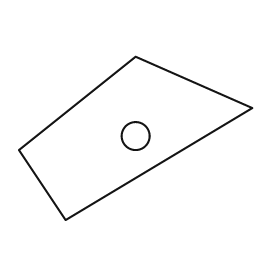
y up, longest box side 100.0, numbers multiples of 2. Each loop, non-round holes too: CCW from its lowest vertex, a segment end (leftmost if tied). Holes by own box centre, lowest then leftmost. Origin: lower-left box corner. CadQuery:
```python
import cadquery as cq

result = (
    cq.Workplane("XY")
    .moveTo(20.0, 0.0)
    .lineTo(100.0, 48.0)
    .lineTo(50.0, 70.0)
    .lineTo(0.0, 30.0)
    .close()
    .moveTo(50.0, 36.0)
    .circle(6.0)
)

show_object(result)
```